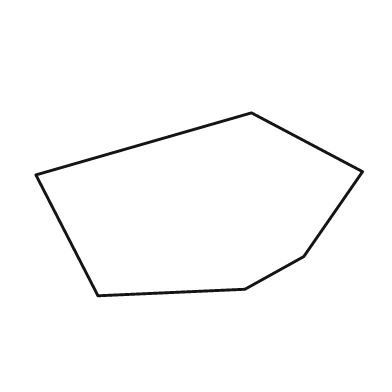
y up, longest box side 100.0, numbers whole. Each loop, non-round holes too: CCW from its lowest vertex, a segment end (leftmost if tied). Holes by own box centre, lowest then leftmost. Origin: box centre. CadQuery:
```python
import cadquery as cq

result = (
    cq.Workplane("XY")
    .moveTo(-31.0, -28.0)
    .lineTo(14.0, -26.0)
    .lineTo(32.0, -16.0)
    .lineTo(50.0, 10.0)
    .lineTo(16.0, 28.0)
    .lineTo(-50.0, 9.0)
    .close()
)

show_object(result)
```